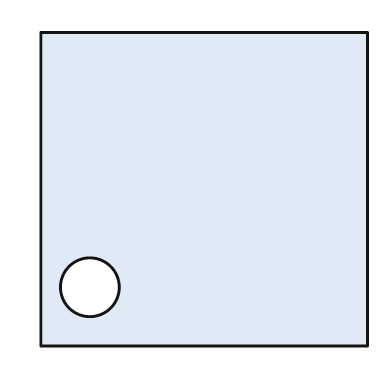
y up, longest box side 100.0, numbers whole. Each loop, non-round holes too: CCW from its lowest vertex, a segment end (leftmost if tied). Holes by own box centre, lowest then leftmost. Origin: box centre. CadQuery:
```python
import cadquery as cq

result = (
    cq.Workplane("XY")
    .moveTo(-50.0, -48.0)
    .lineTo(50.0, -48.0)
    .lineTo(50.0, 48.0)
    .lineTo(-50.0, 48.0)
    .close()
    .moveTo(-35.0, -30.0)
    .circle(9.0)
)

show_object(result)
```